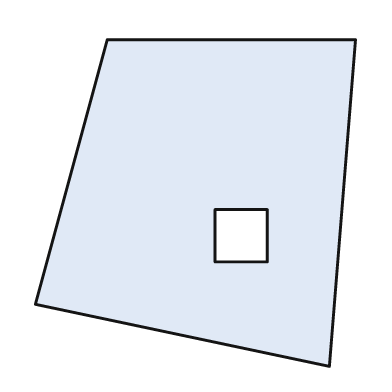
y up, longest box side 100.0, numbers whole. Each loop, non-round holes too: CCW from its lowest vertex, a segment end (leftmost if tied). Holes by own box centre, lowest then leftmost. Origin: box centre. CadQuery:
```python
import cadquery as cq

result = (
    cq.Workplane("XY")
    .moveTo(41.0, -50.0)
    .lineTo(49.0, 50.0)
    .lineTo(-27.0, 50.0)
    .lineTo(-49.0, -31.0)
    .close()
    .moveTo(6.0, -18.0)
    .lineTo(22.0, -18.0)
    .lineTo(22.0, -2.0)
    .lineTo(6.0, -2.0)
    .close()
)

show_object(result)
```